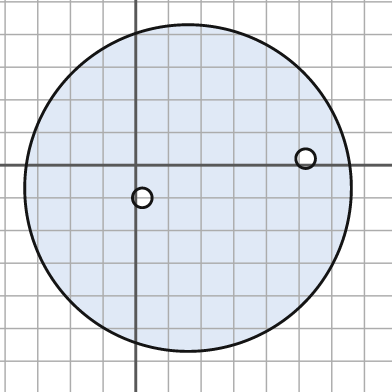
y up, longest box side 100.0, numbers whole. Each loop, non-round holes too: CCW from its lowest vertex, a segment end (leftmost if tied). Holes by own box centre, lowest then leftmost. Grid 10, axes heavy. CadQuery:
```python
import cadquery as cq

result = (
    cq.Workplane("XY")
    .moveTo(16.0, -7.0)
    .circle(50.0)
    .moveTo(2.0, -10.0)
    .circle(3.0)
    .moveTo(52.0, 2.0)
    .circle(3.0)
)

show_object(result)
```